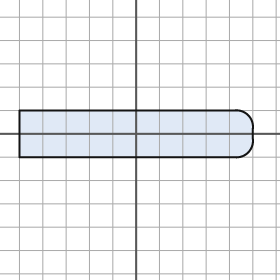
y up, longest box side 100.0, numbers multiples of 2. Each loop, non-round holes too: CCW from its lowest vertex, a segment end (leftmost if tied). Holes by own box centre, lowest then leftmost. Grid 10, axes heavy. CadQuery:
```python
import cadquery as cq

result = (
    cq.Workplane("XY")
    .moveTo(-50.0, -10.0)
    .lineTo(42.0, -10.0)
    .threePointArc((48.0, -8.0), (50.0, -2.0))
    .lineTo(50.0, 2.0)
    .threePointArc((48.0, 8.0), (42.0, 10.0))
    .lineTo(-50.0, 10.0)
    .close()
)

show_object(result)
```